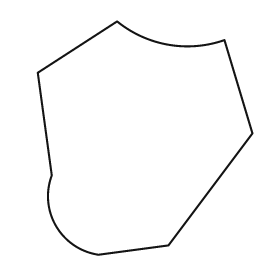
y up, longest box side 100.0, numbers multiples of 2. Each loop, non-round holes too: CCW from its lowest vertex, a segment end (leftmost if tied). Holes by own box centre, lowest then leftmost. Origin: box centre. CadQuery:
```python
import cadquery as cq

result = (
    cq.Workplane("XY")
    .moveTo(-20.0, -50.0)
    .lineTo(10.0, -46.0)
    .lineTo(46.0, 2.0)
    .lineTo(34.0, 42.0)
    .threePointArc((10.0, 40.0), (-12.0, 50.0))
    .lineTo(-46.0, 28.0)
    .lineTo(-40.0, -16.0)
    .threePointArc((-38.0, -38.0), (-20.0, -50.0))
    .close()
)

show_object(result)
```